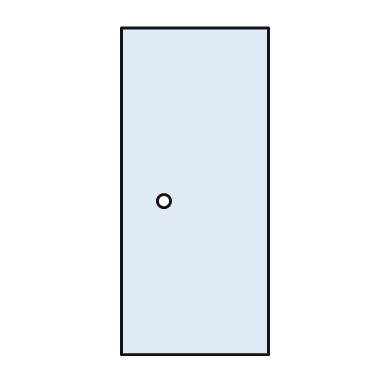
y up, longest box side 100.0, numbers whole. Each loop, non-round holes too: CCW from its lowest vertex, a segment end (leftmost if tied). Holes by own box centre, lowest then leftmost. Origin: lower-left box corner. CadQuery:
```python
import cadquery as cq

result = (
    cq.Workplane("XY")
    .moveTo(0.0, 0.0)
    .lineTo(45.0, 0.0)
    .lineTo(45.0, 100.0)
    .lineTo(0.0, 100.0)
    .close()
    .moveTo(13.0, 47.0)
    .circle(2.0)
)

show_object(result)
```